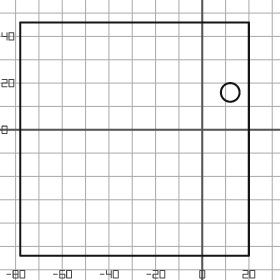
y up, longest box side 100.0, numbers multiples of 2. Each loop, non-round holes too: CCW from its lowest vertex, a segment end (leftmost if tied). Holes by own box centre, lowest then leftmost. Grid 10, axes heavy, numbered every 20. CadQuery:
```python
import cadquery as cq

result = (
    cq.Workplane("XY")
    .moveTo(-78.0, -54.0)
    .lineTo(20.0, -54.0)
    .lineTo(20.0, 46.0)
    .lineTo(-78.0, 46.0)
    .close()
    .moveTo(12.0, 16.0)
    .circle(4.0)
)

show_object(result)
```